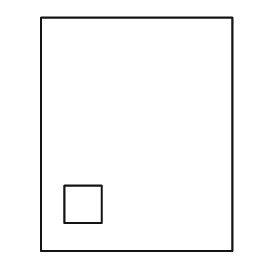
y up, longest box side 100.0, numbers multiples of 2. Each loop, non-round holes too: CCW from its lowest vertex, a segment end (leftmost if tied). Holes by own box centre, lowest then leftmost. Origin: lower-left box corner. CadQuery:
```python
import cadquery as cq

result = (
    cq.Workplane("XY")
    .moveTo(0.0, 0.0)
    .lineTo(82.0, 0.0)
    .lineTo(82.0, 100.0)
    .lineTo(0.0, 100.0)
    .close()
    .moveTo(10.0, 12.0)
    .lineTo(26.0, 12.0)
    .lineTo(26.0, 28.0)
    .lineTo(10.0, 28.0)
    .close()
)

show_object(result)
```